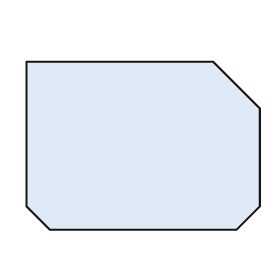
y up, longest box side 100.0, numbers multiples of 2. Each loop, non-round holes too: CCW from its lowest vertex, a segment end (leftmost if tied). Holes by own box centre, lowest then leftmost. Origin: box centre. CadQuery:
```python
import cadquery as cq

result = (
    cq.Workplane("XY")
    .moveTo(-40.0, -36.0)
    .lineTo(40.0, -36.0)
    .lineTo(50.0, -26.0)
    .lineTo(50.0, 16.0)
    .lineTo(30.0, 36.0)
    .lineTo(-50.0, 36.0)
    .lineTo(-50.0, -26.0)
    .close()
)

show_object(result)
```